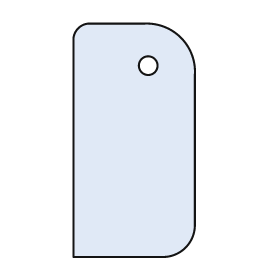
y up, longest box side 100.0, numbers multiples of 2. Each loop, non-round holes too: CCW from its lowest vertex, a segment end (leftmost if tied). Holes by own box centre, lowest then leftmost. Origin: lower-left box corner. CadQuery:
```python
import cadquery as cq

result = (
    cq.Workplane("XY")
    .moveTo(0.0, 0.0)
    .lineTo(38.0, 0.0)
    .threePointArc((48.0, 4.0), (52.0, 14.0))
    .lineTo(52.0, 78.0)
    .threePointArc((46.0, 94.0), (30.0, 100.0))
    .lineTo(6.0, 100.0)
    .threePointArc((2.0, 98.0), (0.0, 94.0))
    .close()
    .moveTo(32.0, 82.0)
    .circle(4.0)
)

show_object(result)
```